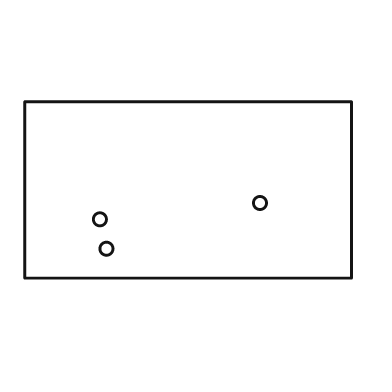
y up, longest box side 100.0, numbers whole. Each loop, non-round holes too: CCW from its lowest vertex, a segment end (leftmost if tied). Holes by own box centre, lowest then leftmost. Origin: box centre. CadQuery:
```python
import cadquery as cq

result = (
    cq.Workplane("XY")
    .moveTo(-50.0, -27.0)
    .lineTo(50.0, -27.0)
    .lineTo(50.0, 27.0)
    .lineTo(-50.0, 27.0)
    .close()
    .moveTo(-25.0, -18.0)
    .circle(2.0)
    .moveTo(-27.0, -9.0)
    .circle(2.0)
    .moveTo(22.0, -4.0)
    .circle(2.0)
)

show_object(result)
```